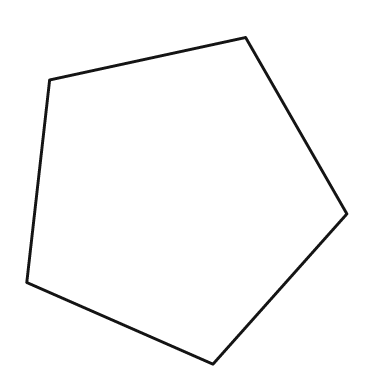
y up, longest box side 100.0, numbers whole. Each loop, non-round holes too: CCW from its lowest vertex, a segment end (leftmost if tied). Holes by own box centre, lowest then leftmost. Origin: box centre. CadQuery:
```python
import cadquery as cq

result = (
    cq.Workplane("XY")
    .moveTo(8.0, -50.0)
    .lineTo(49.0, -4.0)
    .lineTo(18.0, 50.0)
    .lineTo(-42.0, 37.0)
    .lineTo(-49.0, -25.0)
    .close()
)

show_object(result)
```